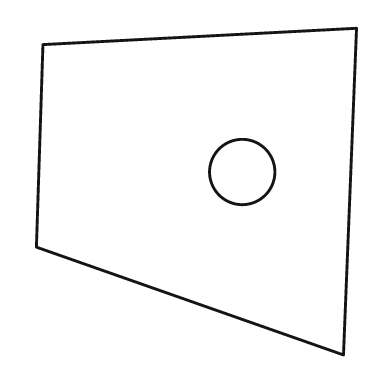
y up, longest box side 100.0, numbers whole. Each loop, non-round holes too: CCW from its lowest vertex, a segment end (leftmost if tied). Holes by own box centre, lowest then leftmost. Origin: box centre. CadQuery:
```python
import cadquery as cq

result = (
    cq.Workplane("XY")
    .moveTo(45.0, -50.0)
    .lineTo(49.0, 50.0)
    .lineTo(-47.0, 45.0)
    .lineTo(-49.0, -17.0)
    .close()
    .moveTo(14.0, 6.0)
    .circle(10.0)
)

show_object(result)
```